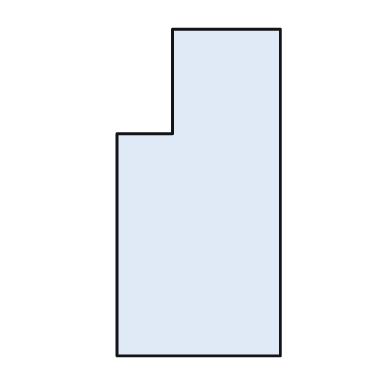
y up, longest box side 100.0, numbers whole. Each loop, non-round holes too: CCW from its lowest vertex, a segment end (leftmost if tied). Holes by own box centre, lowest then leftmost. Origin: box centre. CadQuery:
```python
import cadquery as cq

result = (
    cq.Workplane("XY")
    .moveTo(-25.0, -50.0)
    .lineTo(25.0, -50.0)
    .lineTo(25.0, 50.0)
    .lineTo(-8.0, 50.0)
    .lineTo(-8.0, 18.0)
    .lineTo(-25.0, 18.0)
    .close()
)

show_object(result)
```